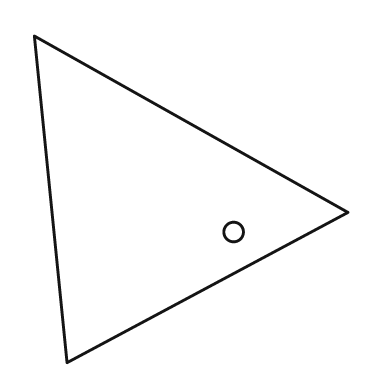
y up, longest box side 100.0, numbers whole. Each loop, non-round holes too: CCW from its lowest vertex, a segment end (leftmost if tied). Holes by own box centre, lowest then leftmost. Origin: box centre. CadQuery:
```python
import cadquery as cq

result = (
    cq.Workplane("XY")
    .moveTo(-38.0, -50.0)
    .lineTo(48.0, -4.0)
    .lineTo(-48.0, 50.0)
    .close()
    .moveTo(13.0, -10.0)
    .circle(3.0)
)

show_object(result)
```